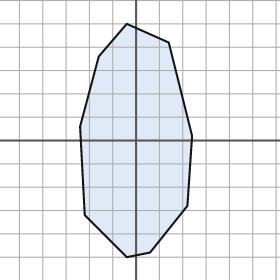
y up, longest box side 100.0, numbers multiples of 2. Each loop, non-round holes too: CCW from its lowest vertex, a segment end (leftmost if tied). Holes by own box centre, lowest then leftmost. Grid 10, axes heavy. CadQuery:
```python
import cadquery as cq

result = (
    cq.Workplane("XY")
    .moveTo(-4.0, -50.0)
    .lineTo(6.0, -48.0)
    .lineTo(22.0, -28.0)
    .lineTo(24.0, 2.0)
    .lineTo(14.0, 42.0)
    .lineTo(-4.0, 50.0)
    .lineTo(-16.0, 36.0)
    .lineTo(-24.0, 6.0)
    .lineTo(-22.0, -32.0)
    .close()
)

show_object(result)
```